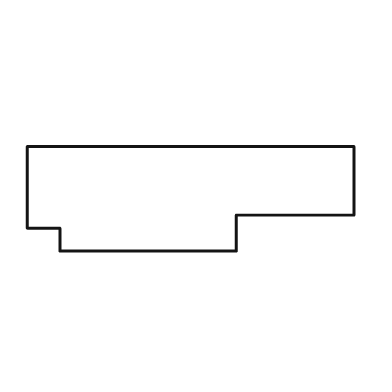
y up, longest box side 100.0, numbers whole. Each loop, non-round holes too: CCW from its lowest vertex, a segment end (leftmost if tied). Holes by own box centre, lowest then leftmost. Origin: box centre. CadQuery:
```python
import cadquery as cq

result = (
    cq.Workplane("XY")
    .moveTo(-40.0, -16.0)
    .lineTo(14.0, -16.0)
    .lineTo(14.0, -5.0)
    .lineTo(50.0, -5.0)
    .lineTo(50.0, 16.0)
    .lineTo(-50.0, 16.0)
    .lineTo(-50.0, -9.0)
    .lineTo(-40.0, -9.0)
    .close()
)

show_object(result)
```